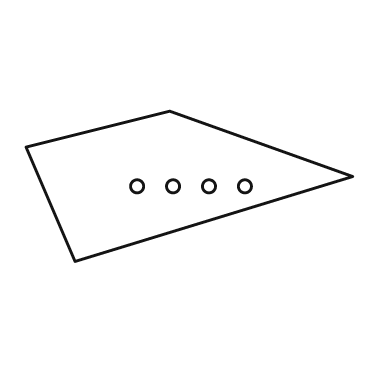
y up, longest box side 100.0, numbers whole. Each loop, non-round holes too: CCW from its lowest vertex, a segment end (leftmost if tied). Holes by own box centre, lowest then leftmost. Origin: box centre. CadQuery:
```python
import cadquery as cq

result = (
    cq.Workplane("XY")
    .moveTo(-35.0, -23.0)
    .lineTo(50.0, 3.0)
    .lineTo(-6.0, 23.0)
    .lineTo(-50.0, 12.0)
    .close()
    .moveTo(-16.0, 0.0)
    .circle(2.0)
    .moveTo(-5.0, 0.0)
    .circle(2.0)
    .moveTo(6.0, 0.0)
    .circle(2.0)
    .moveTo(17.0, 0.0)
    .circle(2.0)
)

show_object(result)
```